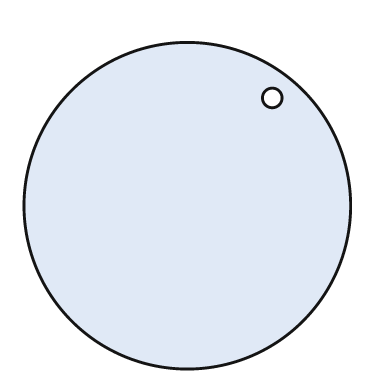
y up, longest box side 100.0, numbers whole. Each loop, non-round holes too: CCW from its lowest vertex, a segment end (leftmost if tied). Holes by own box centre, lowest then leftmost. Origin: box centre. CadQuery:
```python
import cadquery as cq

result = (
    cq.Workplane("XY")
    .moveTo(0.0, 0.0)
    .circle(50.0)
    .moveTo(26.0, 33.0)
    .circle(3.0)
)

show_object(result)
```